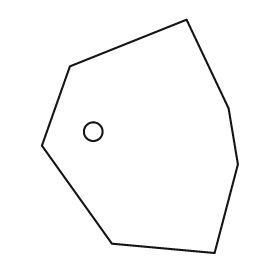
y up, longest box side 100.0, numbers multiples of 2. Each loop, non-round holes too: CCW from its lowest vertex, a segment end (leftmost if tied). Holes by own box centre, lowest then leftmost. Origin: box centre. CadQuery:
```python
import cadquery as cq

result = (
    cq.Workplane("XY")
    .moveTo(32.0, -50.0)
    .lineTo(42.0, -12.0)
    .lineTo(38.0, 12.0)
    .lineTo(20.0, 50.0)
    .lineTo(-30.0, 30.0)
    .lineTo(-42.0, -4.0)
    .lineTo(-12.0, -46.0)
    .close()
    .moveTo(-20.0, 2.0)
    .circle(4.0)
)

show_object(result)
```